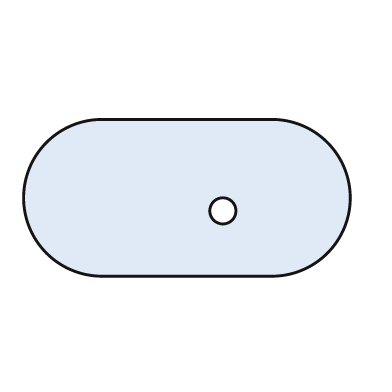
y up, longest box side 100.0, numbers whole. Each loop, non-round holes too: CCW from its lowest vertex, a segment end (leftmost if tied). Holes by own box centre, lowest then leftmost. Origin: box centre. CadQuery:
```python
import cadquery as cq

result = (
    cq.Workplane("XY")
    .moveTo(-26.0, -24.0)
    .lineTo(26.0, -24.0)
    .threePointArc((50.0, 0.0), (26.0, 24.0))
    .lineTo(-26.0, 24.0)
    .threePointArc((-50.0, 0.0), (-26.0, -24.0))
    .close()
    .moveTo(11.0, -4.0)
    .circle(4.0)
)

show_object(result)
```